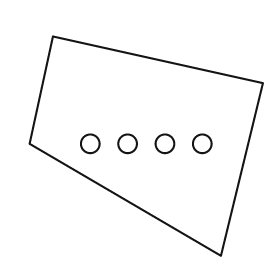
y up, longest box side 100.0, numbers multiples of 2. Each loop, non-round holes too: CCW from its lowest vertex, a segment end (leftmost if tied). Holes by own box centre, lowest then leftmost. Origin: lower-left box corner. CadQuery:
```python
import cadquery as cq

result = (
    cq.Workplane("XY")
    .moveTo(82.0, 0.0)
    .lineTo(100.0, 74.0)
    .lineTo(10.0, 94.0)
    .lineTo(0.0, 48.0)
    .close()
    .moveTo(26.0, 48.0)
    .circle(4.0)
    .moveTo(42.0, 48.0)
    .circle(4.0)
    .moveTo(58.0, 48.0)
    .circle(4.0)
    .moveTo(74.0, 48.0)
    .circle(4.0)
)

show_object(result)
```